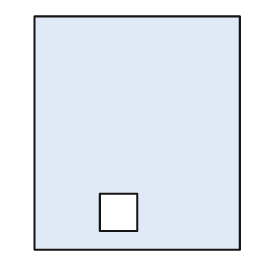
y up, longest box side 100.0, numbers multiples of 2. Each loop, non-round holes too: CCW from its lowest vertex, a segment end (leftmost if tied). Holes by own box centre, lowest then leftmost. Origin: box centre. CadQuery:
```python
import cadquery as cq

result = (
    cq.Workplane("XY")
    .moveTo(-44.0, -50.0)
    .lineTo(44.0, -50.0)
    .lineTo(44.0, 50.0)
    .lineTo(-44.0, 50.0)
    .close()
    .moveTo(-16.0, -42.0)
    .lineTo(0.0, -42.0)
    .lineTo(0.0, -26.0)
    .lineTo(-16.0, -26.0)
    .close()
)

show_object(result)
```